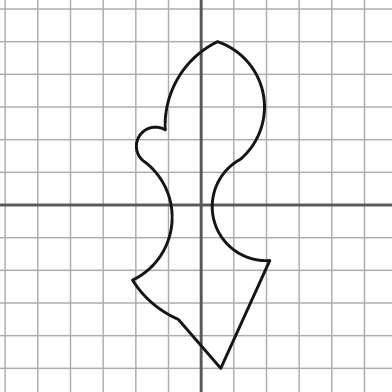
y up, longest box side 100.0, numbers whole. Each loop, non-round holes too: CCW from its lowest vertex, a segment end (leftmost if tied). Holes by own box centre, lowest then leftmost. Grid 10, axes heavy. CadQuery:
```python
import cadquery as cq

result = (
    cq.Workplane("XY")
    .moveTo(6.0, -50.0)
    .lineTo(21.0, -17.0)
    .threePointArc((4.0, -5.0), (12.0, 14.0))
    .threePointArc((19.0, 34.0), (5.0, 50.0))
    .threePointArc((-7.0, 39.0), (-11.0, 23.0))
    .threePointArc((-19.0, 21.0), (-17.0, 13.0))
    .threePointArc((-9.0, -6.0), (-21.0, -23.0))
    .threePointArc((-15.0, -30.0), (-7.0, -35.0))
    .close()
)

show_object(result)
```